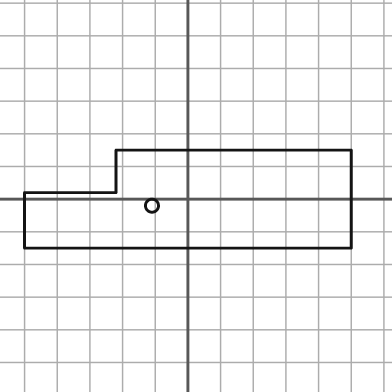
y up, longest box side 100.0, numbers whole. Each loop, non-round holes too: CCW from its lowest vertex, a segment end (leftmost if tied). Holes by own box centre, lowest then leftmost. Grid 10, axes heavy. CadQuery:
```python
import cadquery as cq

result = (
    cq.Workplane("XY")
    .moveTo(-50.0, -15.0)
    .lineTo(50.0, -15.0)
    .lineTo(50.0, 15.0)
    .lineTo(-22.0, 15.0)
    .lineTo(-22.0, 2.0)
    .lineTo(-50.0, 2.0)
    .close()
    .moveTo(-11.0, -2.0)
    .circle(2.0)
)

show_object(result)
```